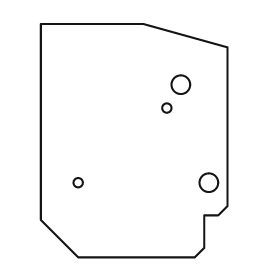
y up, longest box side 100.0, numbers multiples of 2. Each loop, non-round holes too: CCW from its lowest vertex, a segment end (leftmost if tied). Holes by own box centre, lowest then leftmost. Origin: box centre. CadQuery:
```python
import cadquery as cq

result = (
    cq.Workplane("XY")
    .moveTo(-24.0, -50.0)
    .lineTo(26.0, -50.0)
    .lineTo(30.0, -46.0)
    .lineTo(30.0, -32.0)
    .lineTo(36.0, -32.0)
    .lineTo(40.0, -28.0)
    .lineTo(40.0, 40.0)
    .lineTo(4.0, 50.0)
    .lineTo(-40.0, 50.0)
    .lineTo(-40.0, -34.0)
    .close()
    .moveTo(-24.0, -18.0)
    .circle(2.0)
    .moveTo(32.0, -18.0)
    .circle(4.0)
    .moveTo(14.0, 14.0)
    .circle(2.0)
    .moveTo(20.0, 24.0)
    .circle(4.0)
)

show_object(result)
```